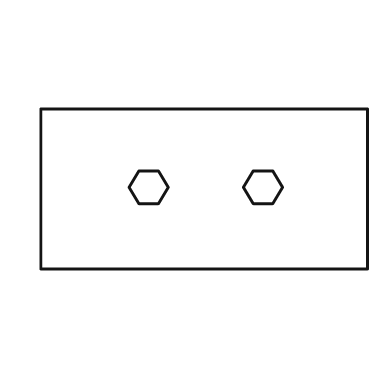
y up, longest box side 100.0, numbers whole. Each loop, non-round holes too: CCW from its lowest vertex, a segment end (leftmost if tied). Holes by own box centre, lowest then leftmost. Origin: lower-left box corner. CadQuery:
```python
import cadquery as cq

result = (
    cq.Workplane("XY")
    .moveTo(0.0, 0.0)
    .lineTo(100.0, 0.0)
    .lineTo(100.0, 49.0)
    .lineTo(0.0, 49.0)
    .close()
    .moveTo(30.0, 20.0)
    .lineTo(36.0, 20.0)
    .lineTo(39.0, 25.0)
    .lineTo(36.0, 30.0)
    .lineTo(30.0, 30.0)
    .lineTo(27.0, 25.0)
    .close()
    .moveTo(65.0, 20.0)
    .lineTo(71.0, 20.0)
    .lineTo(74.0, 25.0)
    .lineTo(71.0, 30.0)
    .lineTo(65.0, 30.0)
    .lineTo(62.0, 25.0)
    .close()
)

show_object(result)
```